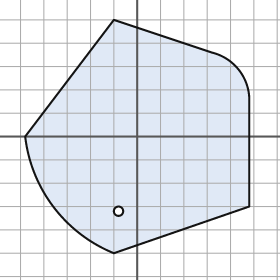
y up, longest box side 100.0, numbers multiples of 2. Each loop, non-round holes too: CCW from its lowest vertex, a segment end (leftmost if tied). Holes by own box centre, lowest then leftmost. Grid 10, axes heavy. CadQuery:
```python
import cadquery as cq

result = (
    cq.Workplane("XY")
    .moveTo(-10.0, -50.0)
    .lineTo(48.0, -30.0)
    .lineTo(48.0, 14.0)
    .threePointArc((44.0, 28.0), (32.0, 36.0))
    .lineTo(-10.0, 50.0)
    .lineTo(-48.0, 0.0)
    .threePointArc((-36.0, -30.0), (-10.0, -50.0))
    .close()
    .moveTo(-8.0, -32.0)
    .circle(2.0)
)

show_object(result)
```